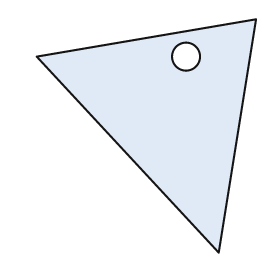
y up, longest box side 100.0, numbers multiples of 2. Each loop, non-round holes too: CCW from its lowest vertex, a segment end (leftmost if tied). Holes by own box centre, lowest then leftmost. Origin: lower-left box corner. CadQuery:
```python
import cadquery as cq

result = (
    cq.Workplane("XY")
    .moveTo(78.0, 0.0)
    .lineTo(94.0, 100.0)
    .lineTo(0.0, 84.0)
    .close()
    .moveTo(64.0, 84.0)
    .circle(6.0)
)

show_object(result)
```